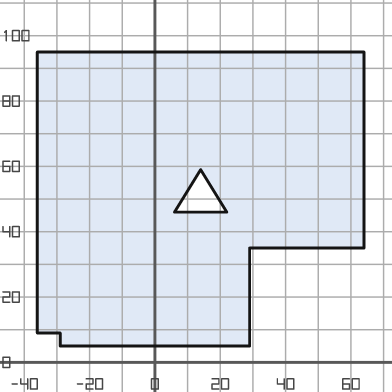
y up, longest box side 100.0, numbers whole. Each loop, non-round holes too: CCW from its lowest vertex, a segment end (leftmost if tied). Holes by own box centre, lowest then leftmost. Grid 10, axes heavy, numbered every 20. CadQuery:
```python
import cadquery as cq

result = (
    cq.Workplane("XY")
    .moveTo(-29.0, 5.0)
    .lineTo(29.0, 5.0)
    .lineTo(29.0, 35.0)
    .lineTo(64.0, 35.0)
    .lineTo(64.0, 95.0)
    .lineTo(-36.0, 95.0)
    .lineTo(-36.0, 9.0)
    .lineTo(-29.0, 9.0)
    .close()
    .moveTo(6.0, 46.0)
    .lineTo(22.0, 46.0)
    .lineTo(14.0, 59.0)
    .close()
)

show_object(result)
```